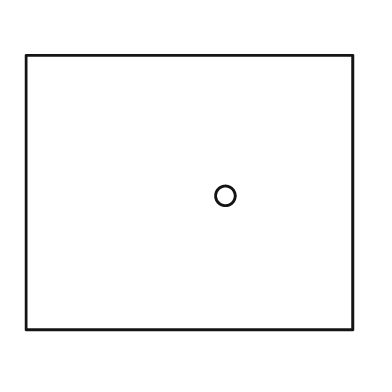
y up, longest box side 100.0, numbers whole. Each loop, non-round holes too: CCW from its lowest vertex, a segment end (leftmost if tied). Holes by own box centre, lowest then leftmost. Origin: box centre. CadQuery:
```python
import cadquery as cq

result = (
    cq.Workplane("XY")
    .moveTo(-50.0, -42.0)
    .lineTo(50.0, -42.0)
    .lineTo(50.0, 42.0)
    .lineTo(-50.0, 42.0)
    .close()
    .moveTo(11.0, -1.0)
    .circle(3.0)
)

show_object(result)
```